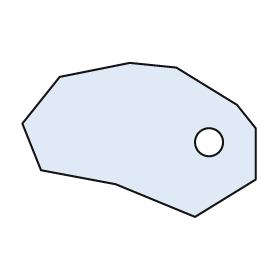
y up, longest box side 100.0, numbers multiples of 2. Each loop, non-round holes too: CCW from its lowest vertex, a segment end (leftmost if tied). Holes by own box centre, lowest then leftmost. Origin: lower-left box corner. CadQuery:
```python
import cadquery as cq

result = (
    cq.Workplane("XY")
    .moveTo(74.0, 0.0)
    .lineTo(100.0, 16.0)
    .lineTo(100.0, 38.0)
    .lineTo(92.0, 48.0)
    .lineTo(66.0, 64.0)
    .lineTo(46.0, 66.0)
    .lineTo(16.0, 60.0)
    .lineTo(0.0, 40.0)
    .lineTo(8.0, 20.0)
    .lineTo(40.0, 14.0)
    .close()
    .moveTo(80.0, 32.0)
    .circle(6.0)
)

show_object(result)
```